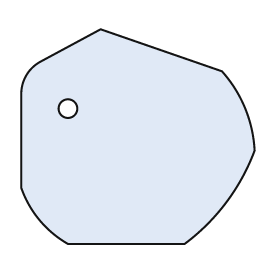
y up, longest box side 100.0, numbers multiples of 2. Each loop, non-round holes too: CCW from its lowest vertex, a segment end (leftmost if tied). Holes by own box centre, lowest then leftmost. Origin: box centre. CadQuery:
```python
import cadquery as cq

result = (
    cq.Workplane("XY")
    .moveTo(-30.0, -46.0)
    .lineTo(20.0, -46.0)
    .threePointArc((38.0, -28.0), (50.0, -6.0))
    .threePointArc((46.0, 12.0), (36.0, 28.0))
    .lineTo(-16.0, 46.0)
    .lineTo(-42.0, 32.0)
    .threePointArc((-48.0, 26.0), (-50.0, 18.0))
    .lineTo(-50.0, -22.0)
    .threePointArc((-42.0, -36.0), (-30.0, -46.0))
    .close()
    .moveTo(-30.0, 12.0)
    .circle(4.0)
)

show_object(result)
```